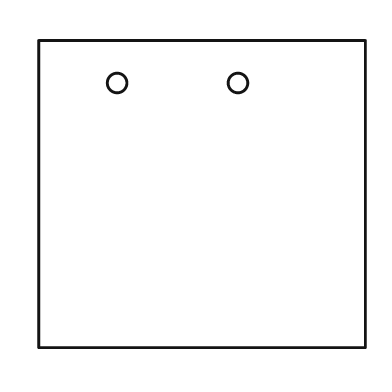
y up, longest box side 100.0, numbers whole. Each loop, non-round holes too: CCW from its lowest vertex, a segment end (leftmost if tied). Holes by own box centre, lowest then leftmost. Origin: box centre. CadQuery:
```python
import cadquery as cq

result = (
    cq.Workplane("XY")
    .moveTo(-50.0, -47.0)
    .lineTo(50.0, -47.0)
    .lineTo(50.0, 47.0)
    .lineTo(-50.0, 47.0)
    .close()
    .moveTo(-26.0, 34.0)
    .circle(3.0)
    .moveTo(11.0, 34.0)
    .circle(3.0)
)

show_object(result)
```